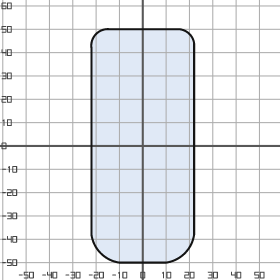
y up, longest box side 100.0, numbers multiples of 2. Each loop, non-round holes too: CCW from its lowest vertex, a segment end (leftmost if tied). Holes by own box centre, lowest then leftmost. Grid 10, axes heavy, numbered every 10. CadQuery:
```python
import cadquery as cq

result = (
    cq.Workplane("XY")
    .moveTo(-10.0, -50.0)
    .lineTo(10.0, -50.0)
    .threePointArc((18.0, -46.0), (22.0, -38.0))
    .lineTo(22.0, 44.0)
    .threePointArc((20.0, 48.0), (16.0, 50.0))
    .lineTo(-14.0, 50.0)
    .threePointArc((-20.0, 48.0), (-22.0, 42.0))
    .lineTo(-22.0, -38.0)
    .threePointArc((-18.0, -46.0), (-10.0, -50.0))
    .close()
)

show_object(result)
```